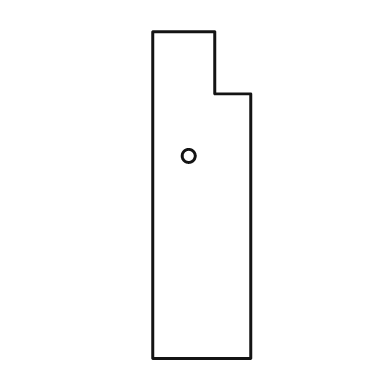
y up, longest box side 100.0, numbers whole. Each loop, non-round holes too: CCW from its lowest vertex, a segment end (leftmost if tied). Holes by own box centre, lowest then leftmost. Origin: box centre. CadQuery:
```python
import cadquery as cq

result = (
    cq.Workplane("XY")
    .moveTo(-15.0, -50.0)
    .lineTo(15.0, -50.0)
    .lineTo(15.0, 31.0)
    .lineTo(4.0, 31.0)
    .lineTo(4.0, 50.0)
    .lineTo(-15.0, 50.0)
    .close()
    .moveTo(-4.0, 12.0)
    .circle(2.0)
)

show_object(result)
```